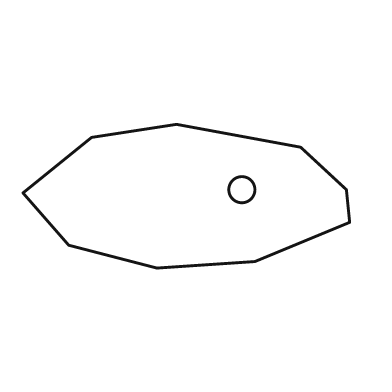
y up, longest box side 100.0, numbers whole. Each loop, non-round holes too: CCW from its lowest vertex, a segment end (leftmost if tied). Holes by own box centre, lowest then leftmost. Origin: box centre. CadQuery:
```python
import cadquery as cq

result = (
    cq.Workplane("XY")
    .moveTo(-9.0, -22.0)
    .lineTo(21.0, -20.0)
    .lineTo(50.0, -8.0)
    .lineTo(49.0, 2.0)
    .lineTo(35.0, 15.0)
    .lineTo(-3.0, 22.0)
    .lineTo(-29.0, 18.0)
    .lineTo(-50.0, 1.0)
    .lineTo(-36.0, -15.0)
    .close()
    .moveTo(17.0, 2.0)
    .circle(4.0)
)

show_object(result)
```